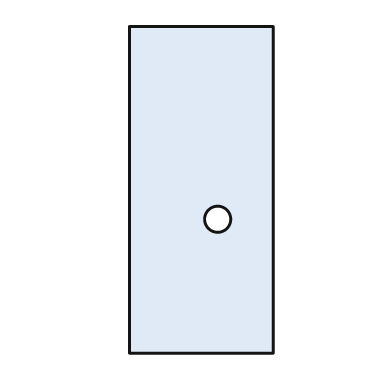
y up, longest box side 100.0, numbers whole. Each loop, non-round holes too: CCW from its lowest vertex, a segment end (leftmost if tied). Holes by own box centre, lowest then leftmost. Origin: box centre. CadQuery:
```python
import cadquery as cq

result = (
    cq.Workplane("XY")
    .moveTo(-22.0, -50.0)
    .lineTo(22.0, -50.0)
    .lineTo(22.0, 50.0)
    .lineTo(-22.0, 50.0)
    .close()
    .moveTo(5.0, -9.0)
    .circle(4.0)
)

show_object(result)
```